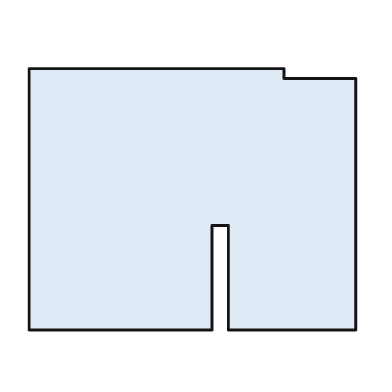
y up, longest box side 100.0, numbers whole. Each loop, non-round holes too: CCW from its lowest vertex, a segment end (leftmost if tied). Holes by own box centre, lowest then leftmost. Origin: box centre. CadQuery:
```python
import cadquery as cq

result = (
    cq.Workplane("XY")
    .moveTo(-50.0, -40.0)
    .lineTo(6.0, -40.0)
    .lineTo(6.0, -8.0)
    .lineTo(11.0, -8.0)
    .lineTo(11.0, -40.0)
    .lineTo(50.0, -40.0)
    .lineTo(50.0, 37.0)
    .lineTo(28.0, 37.0)
    .lineTo(28.0, 40.0)
    .lineTo(-50.0, 40.0)
    .close()
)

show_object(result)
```